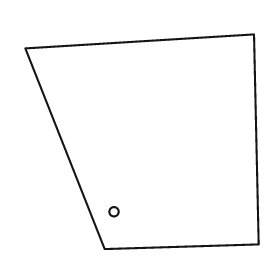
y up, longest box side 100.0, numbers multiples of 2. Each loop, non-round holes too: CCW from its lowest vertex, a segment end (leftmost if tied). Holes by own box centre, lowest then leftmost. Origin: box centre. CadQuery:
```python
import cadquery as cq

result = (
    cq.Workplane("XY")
    .moveTo(-16.0, -46.0)
    .lineTo(50.0, -44.0)
    .lineTo(48.0, 46.0)
    .lineTo(-50.0, 40.0)
    .close()
    .moveTo(-12.0, -30.0)
    .circle(2.0)
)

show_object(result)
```